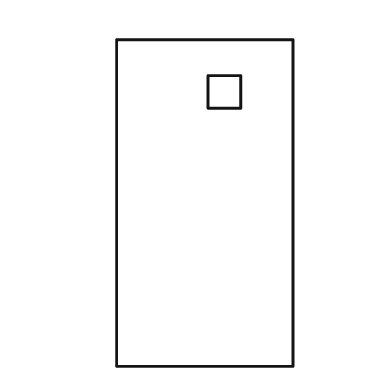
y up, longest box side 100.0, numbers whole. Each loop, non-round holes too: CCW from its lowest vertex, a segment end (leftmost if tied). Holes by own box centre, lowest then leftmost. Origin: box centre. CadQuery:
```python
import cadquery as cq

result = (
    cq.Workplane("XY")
    .moveTo(-27.0, -50.0)
    .lineTo(27.0, -50.0)
    .lineTo(27.0, 50.0)
    .lineTo(-27.0, 50.0)
    .close()
    .moveTo(1.0, 29.0)
    .lineTo(11.0, 29.0)
    .lineTo(11.0, 39.0)
    .lineTo(1.0, 39.0)
    .close()
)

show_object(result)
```